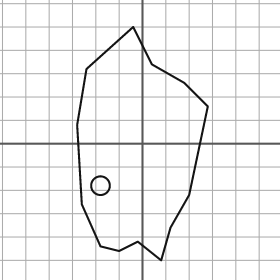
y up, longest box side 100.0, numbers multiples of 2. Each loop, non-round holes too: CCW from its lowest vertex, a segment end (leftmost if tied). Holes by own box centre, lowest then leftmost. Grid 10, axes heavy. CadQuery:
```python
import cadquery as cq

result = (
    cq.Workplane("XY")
    .moveTo(8.0, -50.0)
    .lineTo(12.0, -36.0)
    .lineTo(20.0, -22.0)
    .lineTo(28.0, 16.0)
    .lineTo(18.0, 26.0)
    .lineTo(4.0, 34.0)
    .lineTo(-4.0, 50.0)
    .lineTo(-24.0, 32.0)
    .lineTo(-28.0, 8.0)
    .lineTo(-26.0, -26.0)
    .lineTo(-18.0, -44.0)
    .lineTo(-10.0, -46.0)
    .lineTo(-2.0, -42.0)
    .close()
    .moveTo(-18.0, -18.0)
    .circle(4.0)
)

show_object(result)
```